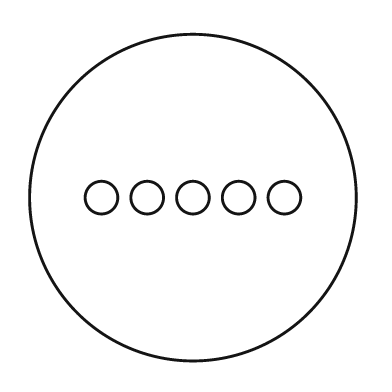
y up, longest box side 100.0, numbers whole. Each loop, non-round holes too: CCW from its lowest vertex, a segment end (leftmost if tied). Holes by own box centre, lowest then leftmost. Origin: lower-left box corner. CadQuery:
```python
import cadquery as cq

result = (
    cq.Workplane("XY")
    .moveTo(50.0, 50.0)
    .circle(50.0)
    .moveTo(22.0, 50.0)
    .circle(5.0)
    .moveTo(36.0, 50.0)
    .circle(5.0)
    .moveTo(50.0, 50.0)
    .circle(5.0)
    .moveTo(64.0, 50.0)
    .circle(5.0)
    .moveTo(78.0, 50.0)
    .circle(5.0)
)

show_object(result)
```